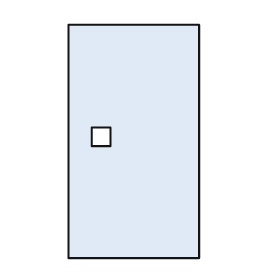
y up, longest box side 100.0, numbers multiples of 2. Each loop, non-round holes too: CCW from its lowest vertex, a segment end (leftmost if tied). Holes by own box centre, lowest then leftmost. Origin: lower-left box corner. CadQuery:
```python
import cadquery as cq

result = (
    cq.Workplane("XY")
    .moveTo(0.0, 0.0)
    .lineTo(56.0, 0.0)
    .lineTo(56.0, 100.0)
    .lineTo(0.0, 100.0)
    .close()
    .moveTo(10.0, 48.0)
    .lineTo(18.0, 48.0)
    .lineTo(18.0, 56.0)
    .lineTo(10.0, 56.0)
    .close()
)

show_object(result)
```